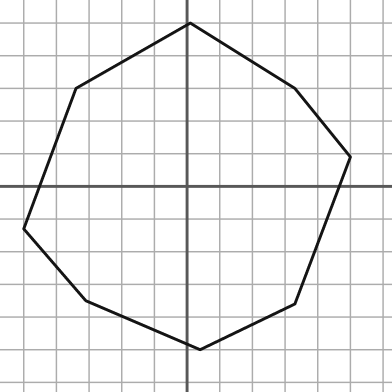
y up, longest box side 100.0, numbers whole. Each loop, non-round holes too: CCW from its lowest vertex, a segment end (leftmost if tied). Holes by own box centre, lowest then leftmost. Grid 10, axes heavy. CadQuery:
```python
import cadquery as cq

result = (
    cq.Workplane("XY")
    .moveTo(4.0, -50.0)
    .lineTo(33.0, -36.0)
    .lineTo(50.0, 9.0)
    .lineTo(33.0, 30.0)
    .lineTo(1.0, 50.0)
    .lineTo(-34.0, 30.0)
    .lineTo(-50.0, -13.0)
    .lineTo(-31.0, -35.0)
    .close()
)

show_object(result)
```